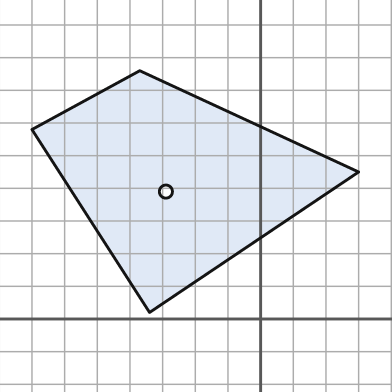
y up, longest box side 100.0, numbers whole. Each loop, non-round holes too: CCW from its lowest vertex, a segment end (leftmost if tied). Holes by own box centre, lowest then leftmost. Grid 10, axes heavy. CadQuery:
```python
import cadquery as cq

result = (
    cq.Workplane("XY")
    .moveTo(-34.0, 2.0)
    .lineTo(30.0, 45.0)
    .lineTo(-37.0, 76.0)
    .lineTo(-70.0, 58.0)
    .close()
    .moveTo(-29.0, 39.0)
    .circle(2.0)
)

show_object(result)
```